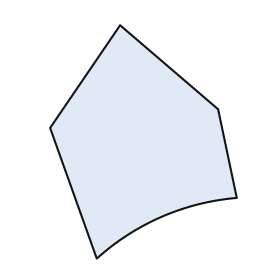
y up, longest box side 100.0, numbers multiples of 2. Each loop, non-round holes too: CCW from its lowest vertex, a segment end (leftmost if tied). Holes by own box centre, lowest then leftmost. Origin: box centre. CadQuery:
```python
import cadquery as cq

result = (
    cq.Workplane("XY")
    .moveTo(-20.0, -50.0)
    .threePointArc((8.0, -32.0), (40.0, -24.0))
    .lineTo(32.0, 14.0)
    .lineTo(-10.0, 50.0)
    .lineTo(-40.0, 6.0)
    .close()
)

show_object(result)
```